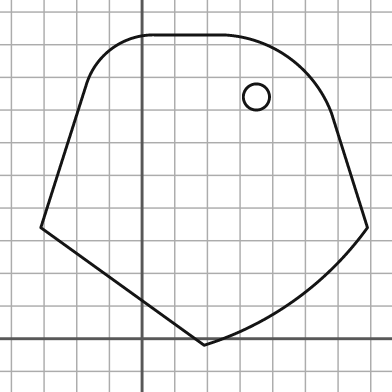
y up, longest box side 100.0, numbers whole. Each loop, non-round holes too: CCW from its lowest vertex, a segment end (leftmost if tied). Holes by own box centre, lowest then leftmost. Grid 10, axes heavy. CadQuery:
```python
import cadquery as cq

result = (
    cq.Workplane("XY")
    .moveTo(19.0, -2.0)
    .threePointArc((47.0, 12.0), (69.0, 34.0))
    .lineTo(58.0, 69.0)
    .threePointArc((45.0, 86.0), (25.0, 93.0))
    .lineTo(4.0, 93.0)
    .threePointArc((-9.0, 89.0), (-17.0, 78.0))
    .lineTo(-31.0, 34.0)
    .close()
    .moveTo(35.0, 74.0)
    .circle(4.0)
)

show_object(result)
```